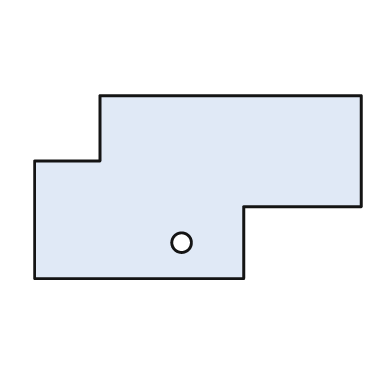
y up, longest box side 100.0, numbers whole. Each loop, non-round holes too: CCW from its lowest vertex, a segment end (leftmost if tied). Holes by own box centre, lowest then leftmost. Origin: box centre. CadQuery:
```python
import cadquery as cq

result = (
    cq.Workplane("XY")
    .moveTo(-50.0, -28.0)
    .lineTo(14.0, -28.0)
    .lineTo(14.0, -6.0)
    .lineTo(50.0, -6.0)
    .lineTo(50.0, 28.0)
    .lineTo(-30.0, 28.0)
    .lineTo(-30.0, 8.0)
    .lineTo(-50.0, 8.0)
    .close()
    .moveTo(-5.0, -17.0)
    .circle(3.0)
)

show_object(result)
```